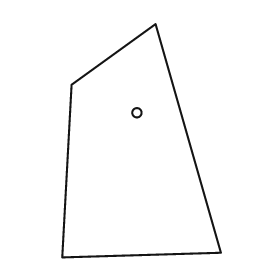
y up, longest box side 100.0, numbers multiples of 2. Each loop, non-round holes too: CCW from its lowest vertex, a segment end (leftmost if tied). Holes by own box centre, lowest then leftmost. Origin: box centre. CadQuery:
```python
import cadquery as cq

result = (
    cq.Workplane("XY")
    .moveTo(-34.0, -50.0)
    .lineTo(34.0, -48.0)
    .lineTo(6.0, 50.0)
    .lineTo(-30.0, 24.0)
    .close()
    .moveTo(-2.0, 12.0)
    .circle(2.0)
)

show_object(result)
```